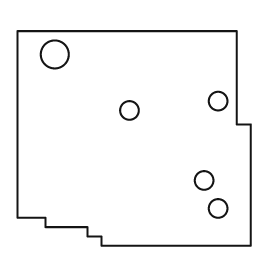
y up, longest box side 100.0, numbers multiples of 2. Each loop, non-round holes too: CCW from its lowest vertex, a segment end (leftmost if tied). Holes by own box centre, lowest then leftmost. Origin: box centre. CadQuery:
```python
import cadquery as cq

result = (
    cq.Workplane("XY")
    .moveTo(-14.0, -46.0)
    .lineTo(50.0, -46.0)
    .lineTo(50.0, 6.0)
    .lineTo(44.0, 6.0)
    .lineTo(44.0, 46.0)
    .lineTo(-50.0, 46.0)
    .lineTo(-50.0, -34.0)
    .lineTo(-38.0, -34.0)
    .lineTo(-38.0, -38.0)
    .lineTo(-20.0, -38.0)
    .lineTo(-20.0, -42.0)
    .lineTo(-14.0, -42.0)
    .close()
    .moveTo(36.0, -30.0)
    .circle(4.0)
    .moveTo(30.0, -18.0)
    .circle(4.0)
    .moveTo(-2.0, 12.0)
    .circle(4.0)
    .moveTo(36.0, 16.0)
    .circle(4.0)
    .moveTo(-34.0, 36.0)
    .circle(6.0)
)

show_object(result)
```